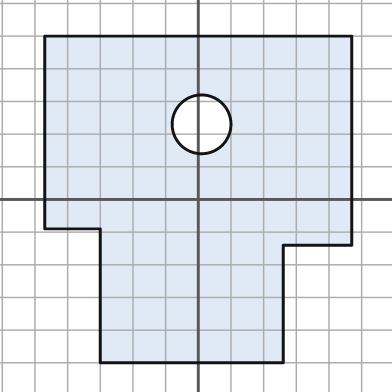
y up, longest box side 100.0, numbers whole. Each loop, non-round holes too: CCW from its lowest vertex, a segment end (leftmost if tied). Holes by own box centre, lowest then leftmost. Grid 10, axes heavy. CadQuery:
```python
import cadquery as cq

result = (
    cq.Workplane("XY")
    .moveTo(-30.0, -50.0)
    .lineTo(26.0, -50.0)
    .lineTo(26.0, -14.0)
    .lineTo(47.0, -14.0)
    .lineTo(47.0, 50.0)
    .lineTo(-47.0, 50.0)
    .lineTo(-47.0, -9.0)
    .lineTo(-30.0, -9.0)
    .close()
    .moveTo(1.0, 23.0)
    .circle(9.0)
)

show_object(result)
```